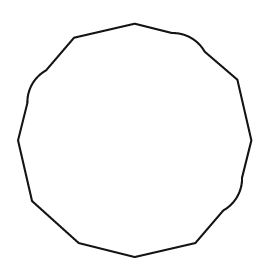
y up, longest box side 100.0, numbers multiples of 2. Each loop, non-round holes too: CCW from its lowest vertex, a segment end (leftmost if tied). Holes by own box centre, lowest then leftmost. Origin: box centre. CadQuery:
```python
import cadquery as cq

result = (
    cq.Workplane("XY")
    .moveTo(0.0, -50.0)
    .lineTo(26.0, -44.0)
    .lineTo(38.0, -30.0)
    .threePointArc((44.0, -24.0), (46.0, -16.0))
    .lineTo(50.0, 0.0)
    .lineTo(44.0, 26.0)
    .lineTo(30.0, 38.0)
    .threePointArc((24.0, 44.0), (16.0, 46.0))
    .lineTo(0.0, 50.0)
    .lineTo(-26.0, 44.0)
    .lineTo(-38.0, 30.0)
    .threePointArc((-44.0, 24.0), (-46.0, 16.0))
    .lineTo(-50.0, 0.0)
    .lineTo(-44.0, -26.0)
    .lineTo(-24.0, -44.0)
    .close()
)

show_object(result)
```